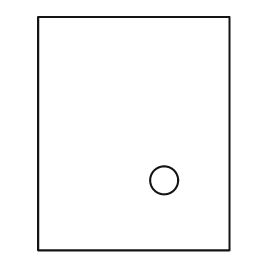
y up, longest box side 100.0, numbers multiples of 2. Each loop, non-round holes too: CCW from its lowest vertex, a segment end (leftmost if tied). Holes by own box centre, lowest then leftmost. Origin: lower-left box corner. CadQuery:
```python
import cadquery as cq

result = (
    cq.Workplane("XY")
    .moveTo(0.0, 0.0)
    .lineTo(82.0, 0.0)
    .lineTo(82.0, 100.0)
    .lineTo(0.0, 100.0)
    .close()
    .moveTo(54.0, 30.0)
    .circle(6.0)
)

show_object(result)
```